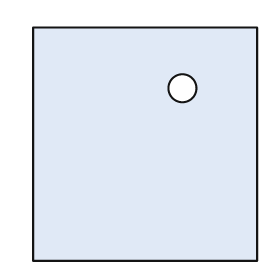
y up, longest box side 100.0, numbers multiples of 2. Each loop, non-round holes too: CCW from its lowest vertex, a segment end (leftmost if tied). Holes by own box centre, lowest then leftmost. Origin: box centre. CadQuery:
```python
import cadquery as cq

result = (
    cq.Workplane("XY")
    .moveTo(-48.0, -50.0)
    .lineTo(48.0, -50.0)
    .lineTo(48.0, 50.0)
    .lineTo(-48.0, 50.0)
    .close()
    .moveTo(16.0, 24.0)
    .circle(6.0)
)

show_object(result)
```